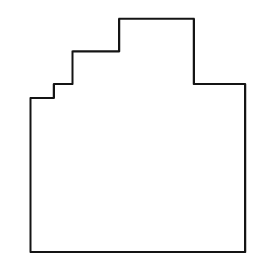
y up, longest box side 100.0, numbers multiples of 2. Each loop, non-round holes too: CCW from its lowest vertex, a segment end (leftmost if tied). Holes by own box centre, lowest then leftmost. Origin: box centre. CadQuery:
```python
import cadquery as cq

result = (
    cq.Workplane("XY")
    .moveTo(-46.0, -50.0)
    .lineTo(46.0, -50.0)
    .lineTo(46.0, 22.0)
    .lineTo(24.0, 22.0)
    .lineTo(24.0, 50.0)
    .lineTo(-8.0, 50.0)
    .lineTo(-8.0, 36.0)
    .lineTo(-28.0, 36.0)
    .lineTo(-28.0, 22.0)
    .lineTo(-36.0, 22.0)
    .lineTo(-36.0, 16.0)
    .lineTo(-46.0, 16.0)
    .close()
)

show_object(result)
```